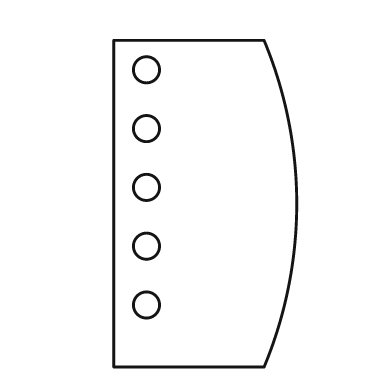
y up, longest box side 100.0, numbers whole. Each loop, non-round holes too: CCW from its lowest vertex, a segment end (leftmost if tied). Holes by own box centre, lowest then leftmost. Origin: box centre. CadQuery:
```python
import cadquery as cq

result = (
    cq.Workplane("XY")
    .moveTo(-28.0, -50.0)
    .lineTo(18.0, -50.0)
    .threePointArc((28.0, 0.0), (18.0, 50.0))
    .lineTo(-28.0, 50.0)
    .close()
    .moveTo(-18.0, -31.0)
    .circle(4.0)
    .moveTo(-18.0, -13.0)
    .circle(4.0)
    .moveTo(-18.0, 5.0)
    .circle(4.0)
    .moveTo(-18.0, 23.0)
    .circle(4.0)
    .moveTo(-18.0, 41.0)
    .circle(4.0)
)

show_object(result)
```